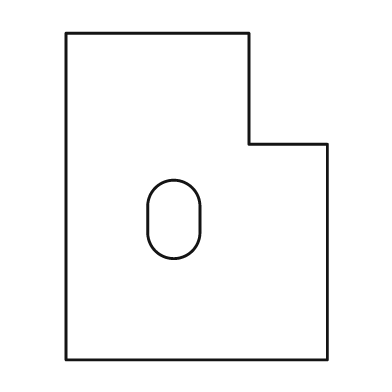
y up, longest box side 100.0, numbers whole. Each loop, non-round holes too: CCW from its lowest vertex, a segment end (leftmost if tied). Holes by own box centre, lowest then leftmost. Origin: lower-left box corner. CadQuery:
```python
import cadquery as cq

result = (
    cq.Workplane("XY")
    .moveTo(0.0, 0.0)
    .lineTo(80.0, 0.0)
    .lineTo(80.0, 66.0)
    .lineTo(56.0, 66.0)
    .lineTo(56.0, 100.0)
    .lineTo(0.0, 100.0)
    .close()
    .moveTo(25.0, 39.0)
    .threePointArc((33.0, 31.0), (41.0, 39.0))
    .lineTo(41.0, 47.0)
    .threePointArc((33.0, 55.0), (25.0, 47.0))
    .close()
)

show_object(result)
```